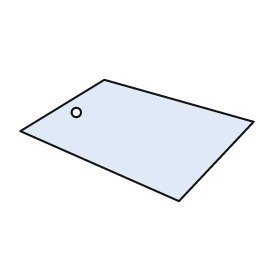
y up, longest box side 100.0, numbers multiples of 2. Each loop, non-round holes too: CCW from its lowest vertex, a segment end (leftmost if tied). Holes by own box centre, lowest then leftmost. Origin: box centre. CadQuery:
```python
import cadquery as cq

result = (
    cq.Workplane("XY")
    .moveTo(18.0, -26.0)
    .lineTo(50.0, 8.0)
    .lineTo(-14.0, 26.0)
    .lineTo(-50.0, 4.0)
    .close()
    .moveTo(-26.0, 12.0)
    .circle(2.0)
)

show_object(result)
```